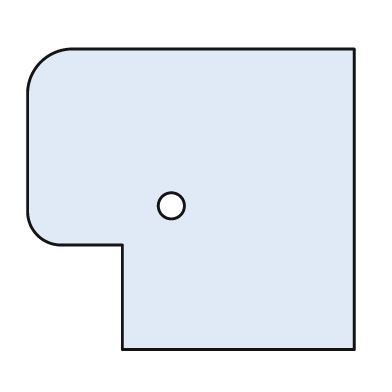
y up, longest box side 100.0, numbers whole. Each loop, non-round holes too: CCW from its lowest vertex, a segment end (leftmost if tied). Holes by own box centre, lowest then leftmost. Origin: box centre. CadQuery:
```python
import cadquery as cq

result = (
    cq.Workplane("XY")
    .moveTo(-21.0, -46.0)
    .lineTo(50.0, -46.0)
    .lineTo(50.0, 46.0)
    .lineTo(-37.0, 46.0)
    .threePointArc((-46.0, 42.0), (-50.0, 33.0))
    .lineTo(-50.0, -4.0)
    .threePointArc((-47.0, -11.0), (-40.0, -14.0))
    .lineTo(-21.0, -14.0)
    .close()
    .moveTo(-6.0, -2.0)
    .circle(4.0)
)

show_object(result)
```